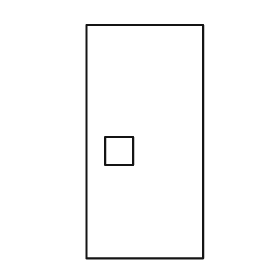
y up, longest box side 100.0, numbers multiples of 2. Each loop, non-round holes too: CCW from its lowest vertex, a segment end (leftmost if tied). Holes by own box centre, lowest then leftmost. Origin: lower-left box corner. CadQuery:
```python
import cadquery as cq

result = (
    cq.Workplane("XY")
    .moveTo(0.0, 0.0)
    .lineTo(50.0, 0.0)
    .lineTo(50.0, 100.0)
    .lineTo(0.0, 100.0)
    .close()
    .moveTo(8.0, 40.0)
    .lineTo(20.0, 40.0)
    .lineTo(20.0, 52.0)
    .lineTo(8.0, 52.0)
    .close()
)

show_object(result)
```